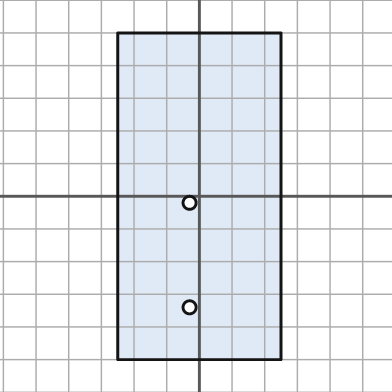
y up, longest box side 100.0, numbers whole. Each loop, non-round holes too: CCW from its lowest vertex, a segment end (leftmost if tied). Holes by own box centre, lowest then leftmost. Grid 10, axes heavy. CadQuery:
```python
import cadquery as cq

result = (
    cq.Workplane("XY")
    .moveTo(-25.0, -50.0)
    .lineTo(25.0, -50.0)
    .lineTo(25.0, 50.0)
    .lineTo(-25.0, 50.0)
    .close()
    .moveTo(-3.0, -34.0)
    .circle(2.0)
    .moveTo(-3.0, -2.0)
    .circle(2.0)
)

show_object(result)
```